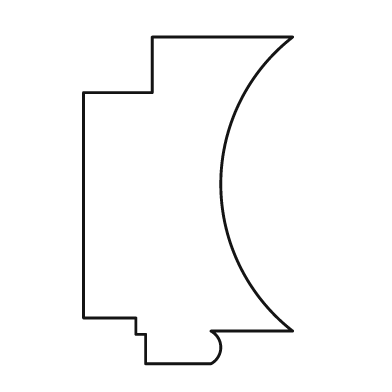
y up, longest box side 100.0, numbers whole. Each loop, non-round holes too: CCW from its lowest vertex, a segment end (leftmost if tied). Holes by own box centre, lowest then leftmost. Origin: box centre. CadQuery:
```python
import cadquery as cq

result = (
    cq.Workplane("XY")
    .moveTo(-13.0, -50.0)
    .lineTo(7.0, -50.0)
    .threePointArc((10.0, -45.0), (7.0, -40.0))
    .lineTo(32.0, -40.0)
    .threePointArc((10.0, 5.0), (32.0, 50.0))
    .lineTo(-11.0, 50.0)
    .lineTo(-11.0, 33.0)
    .lineTo(-32.0, 33.0)
    .lineTo(-32.0, -36.0)
    .lineTo(-16.0, -36.0)
    .lineTo(-16.0, -41.0)
    .lineTo(-13.0, -41.0)
    .close()
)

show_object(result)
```